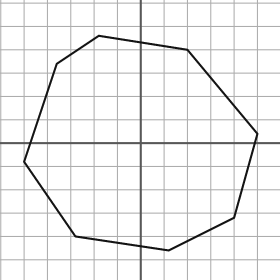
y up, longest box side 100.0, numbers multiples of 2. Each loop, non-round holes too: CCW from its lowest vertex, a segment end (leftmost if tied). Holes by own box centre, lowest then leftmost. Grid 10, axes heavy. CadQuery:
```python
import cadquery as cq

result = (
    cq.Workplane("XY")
    .moveTo(12.0, -46.0)
    .lineTo(40.0, -32.0)
    .lineTo(50.0, 4.0)
    .lineTo(20.0, 40.0)
    .lineTo(-18.0, 46.0)
    .lineTo(-36.0, 34.0)
    .lineTo(-50.0, -8.0)
    .lineTo(-28.0, -40.0)
    .close()
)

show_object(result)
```